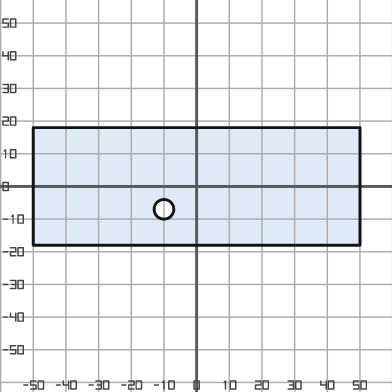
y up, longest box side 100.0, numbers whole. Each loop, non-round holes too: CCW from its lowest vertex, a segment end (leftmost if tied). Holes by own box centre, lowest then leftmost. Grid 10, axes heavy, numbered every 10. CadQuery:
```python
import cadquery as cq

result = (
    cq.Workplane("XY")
    .moveTo(-50.0, -18.0)
    .lineTo(50.0, -18.0)
    .lineTo(50.0, 18.0)
    .lineTo(-50.0, 18.0)
    .close()
    .moveTo(-10.0, -7.0)
    .circle(3.0)
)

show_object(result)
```